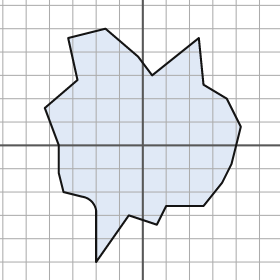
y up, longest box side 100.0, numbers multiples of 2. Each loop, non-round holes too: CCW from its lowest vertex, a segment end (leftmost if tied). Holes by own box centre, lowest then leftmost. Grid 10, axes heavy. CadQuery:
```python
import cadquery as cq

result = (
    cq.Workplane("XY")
    .moveTo(-20.0, -50.0)
    .lineTo(-6.0, -30.0)
    .lineTo(6.0, -34.0)
    .lineTo(10.0, -26.0)
    .lineTo(26.0, -26.0)
    .lineTo(34.0, -16.0)
    .lineTo(38.0, -8.0)
    .lineTo(42.0, 8.0)
    .lineTo(36.0, 20.0)
    .lineTo(26.0, 26.0)
    .lineTo(24.0, 46.0)
    .lineTo(4.0, 30.0)
    .lineTo(-2.0, 38.0)
    .lineTo(-16.0, 50.0)
    .lineTo(-32.0, 46.0)
    .lineTo(-28.0, 28.0)
    .lineTo(-42.0, 16.0)
    .lineTo(-36.0, 0.0)
    .lineTo(-36.0, -12.0)
    .lineTo(-34.0, -20.0)
    .lineTo(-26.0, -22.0)
    .threePointArc((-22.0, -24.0), (-20.0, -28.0))
    .close()
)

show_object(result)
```